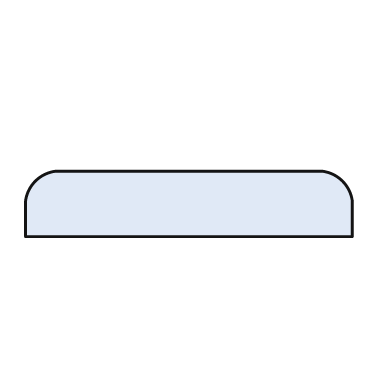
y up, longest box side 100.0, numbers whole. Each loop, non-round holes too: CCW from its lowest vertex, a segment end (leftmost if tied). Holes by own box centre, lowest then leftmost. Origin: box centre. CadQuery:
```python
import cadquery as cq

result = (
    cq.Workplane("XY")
    .moveTo(-50.0, -10.0)
    .lineTo(50.0, -10.0)
    .lineTo(50.0, 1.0)
    .threePointArc((47.0, 7.0), (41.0, 10.0))
    .lineTo(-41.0, 10.0)
    .threePointArc((-47.0, 7.0), (-50.0, 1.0))
    .close()
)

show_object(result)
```